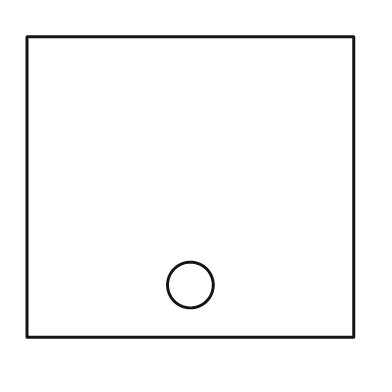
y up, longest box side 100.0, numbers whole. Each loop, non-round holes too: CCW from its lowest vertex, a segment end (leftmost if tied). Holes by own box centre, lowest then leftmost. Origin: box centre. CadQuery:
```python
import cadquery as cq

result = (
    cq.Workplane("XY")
    .moveTo(-50.0, -46.0)
    .lineTo(50.0, -46.0)
    .lineTo(50.0, 46.0)
    .lineTo(-50.0, 46.0)
    .close()
    .moveTo(0.0, -30.0)
    .circle(7.0)
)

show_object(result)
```